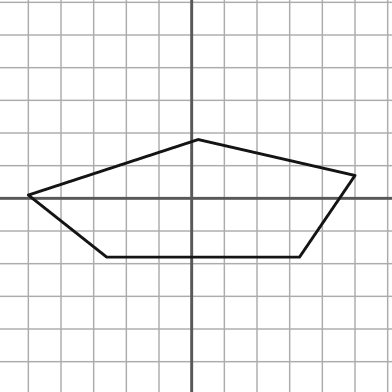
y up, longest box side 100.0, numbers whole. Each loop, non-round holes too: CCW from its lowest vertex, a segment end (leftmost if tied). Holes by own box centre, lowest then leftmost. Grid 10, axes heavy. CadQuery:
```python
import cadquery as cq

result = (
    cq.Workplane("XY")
    .moveTo(-26.0, -18.0)
    .lineTo(33.0, -18.0)
    .lineTo(50.0, 7.0)
    .lineTo(2.0, 18.0)
    .lineTo(-50.0, 1.0)
    .close()
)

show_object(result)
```